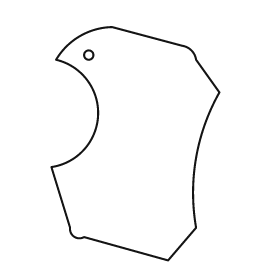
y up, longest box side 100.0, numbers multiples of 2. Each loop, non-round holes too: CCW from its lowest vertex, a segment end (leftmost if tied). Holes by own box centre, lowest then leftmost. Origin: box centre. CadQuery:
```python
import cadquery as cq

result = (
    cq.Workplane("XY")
    .moveTo(14.0, -50.0)
    .lineTo(26.0, -36.0)
    .threePointArc((26.0, -6.0), (36.0, 22.0))
    .lineTo(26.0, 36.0)
    .threePointArc((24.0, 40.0), (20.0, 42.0))
    .lineTo(-10.0, 50.0)
    .threePointArc((-24.0, 46.0), (-34.0, 36.0))
    .threePointArc((-16.0, 12.0), (-36.0, -10.0))
    .lineTo(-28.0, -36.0)
    .threePointArc((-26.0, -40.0), (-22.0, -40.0))
    .close()
    .moveTo(-20.0, 38.0)
    .circle(2.0)
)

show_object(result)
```